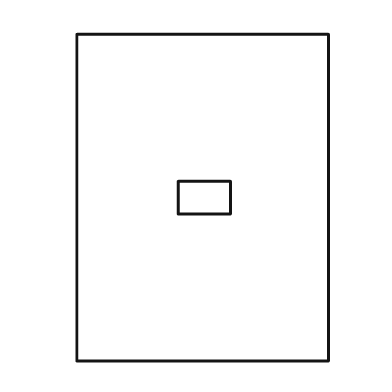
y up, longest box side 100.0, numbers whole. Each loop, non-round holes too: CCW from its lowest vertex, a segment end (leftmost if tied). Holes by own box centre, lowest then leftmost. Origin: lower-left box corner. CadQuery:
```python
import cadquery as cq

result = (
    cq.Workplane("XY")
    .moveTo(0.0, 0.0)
    .lineTo(77.0, 0.0)
    .lineTo(77.0, 100.0)
    .lineTo(0.0, 100.0)
    .close()
    .moveTo(31.0, 45.0)
    .lineTo(47.0, 45.0)
    .lineTo(47.0, 55.0)
    .lineTo(31.0, 55.0)
    .close()
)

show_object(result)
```